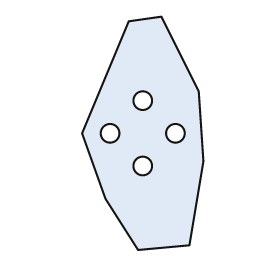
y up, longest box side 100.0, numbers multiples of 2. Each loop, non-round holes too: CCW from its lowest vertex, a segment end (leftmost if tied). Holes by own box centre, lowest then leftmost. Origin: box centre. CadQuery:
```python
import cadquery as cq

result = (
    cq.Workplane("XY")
    .moveTo(-2.0, -50.0)
    .lineTo(20.0, -48.0)
    .lineTo(26.0, -12.0)
    .lineTo(24.0, 18.0)
    .lineTo(8.0, 50.0)
    .lineTo(-6.0, 48.0)
    .lineTo(-26.0, 0.0)
    .lineTo(-16.0, -28.0)
    .close()
    .moveTo(0.0, -14.0)
    .circle(4.0)
    .moveTo(-14.0, 0.0)
    .circle(4.0)
    .moveTo(14.0, 0.0)
    .circle(4.0)
    .moveTo(0.0, 14.0)
    .circle(4.0)
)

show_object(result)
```